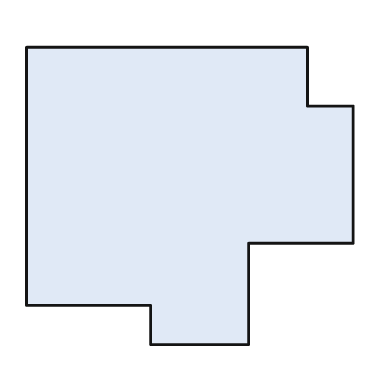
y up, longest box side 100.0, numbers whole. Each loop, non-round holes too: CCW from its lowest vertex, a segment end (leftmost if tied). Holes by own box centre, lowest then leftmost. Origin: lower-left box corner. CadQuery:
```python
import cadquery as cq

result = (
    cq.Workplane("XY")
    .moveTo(38.0, 0.0)
    .lineTo(68.0, 0.0)
    .lineTo(68.0, 31.0)
    .lineTo(100.0, 31.0)
    .lineTo(100.0, 73.0)
    .lineTo(86.0, 73.0)
    .lineTo(86.0, 91.0)
    .lineTo(0.0, 91.0)
    .lineTo(0.0, 12.0)
    .lineTo(38.0, 12.0)
    .close()
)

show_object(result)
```